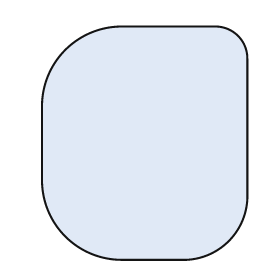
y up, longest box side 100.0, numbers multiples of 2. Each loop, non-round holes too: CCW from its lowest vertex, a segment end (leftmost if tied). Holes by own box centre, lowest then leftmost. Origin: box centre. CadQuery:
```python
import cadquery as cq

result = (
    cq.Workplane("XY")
    .moveTo(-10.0, -50.0)
    .lineTo(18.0, -50.0)
    .threePointArc((36.0, -42.0), (44.0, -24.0))
    .lineTo(44.0, 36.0)
    .threePointArc((40.0, 46.0), (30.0, 50.0))
    .lineTo(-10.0, 50.0)
    .threePointArc((-34.0, 40.0), (-44.0, 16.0))
    .lineTo(-44.0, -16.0)
    .threePointArc((-34.0, -40.0), (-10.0, -50.0))
    .close()
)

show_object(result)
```